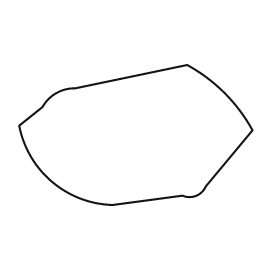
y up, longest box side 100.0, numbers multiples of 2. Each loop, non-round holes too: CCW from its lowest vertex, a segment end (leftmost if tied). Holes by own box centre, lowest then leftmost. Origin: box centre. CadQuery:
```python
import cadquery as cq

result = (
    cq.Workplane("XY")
    .moveTo(-10.0, -30.0)
    .lineTo(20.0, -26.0)
    .threePointArc((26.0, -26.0), (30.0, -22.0))
    .lineTo(50.0, 2.0)
    .threePointArc((38.0, 18.0), (22.0, 30.0))
    .lineTo(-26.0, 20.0)
    .threePointArc((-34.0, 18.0), (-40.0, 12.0))
    .lineTo(-50.0, 4.0)
    .threePointArc((-36.0, -20.0), (-10.0, -30.0))
    .close()
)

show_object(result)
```